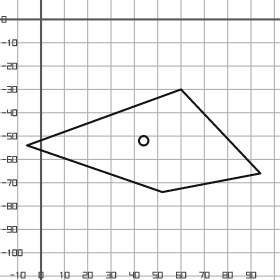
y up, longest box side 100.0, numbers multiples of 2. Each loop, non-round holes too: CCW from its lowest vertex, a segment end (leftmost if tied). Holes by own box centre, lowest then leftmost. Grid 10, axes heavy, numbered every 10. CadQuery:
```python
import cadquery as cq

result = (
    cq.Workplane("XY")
    .moveTo(52.0, -74.0)
    .lineTo(94.0, -66.0)
    .lineTo(60.0, -30.0)
    .lineTo(-6.0, -54.0)
    .close()
    .moveTo(44.0, -52.0)
    .circle(2.0)
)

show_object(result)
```